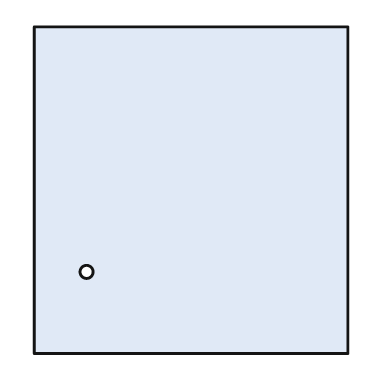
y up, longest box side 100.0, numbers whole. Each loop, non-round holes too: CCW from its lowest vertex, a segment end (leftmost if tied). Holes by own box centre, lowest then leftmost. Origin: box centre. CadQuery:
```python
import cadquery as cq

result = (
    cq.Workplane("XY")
    .moveTo(-48.0, -50.0)
    .lineTo(48.0, -50.0)
    .lineTo(48.0, 50.0)
    .lineTo(-48.0, 50.0)
    .close()
    .moveTo(-32.0, -25.0)
    .circle(2.0)
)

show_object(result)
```